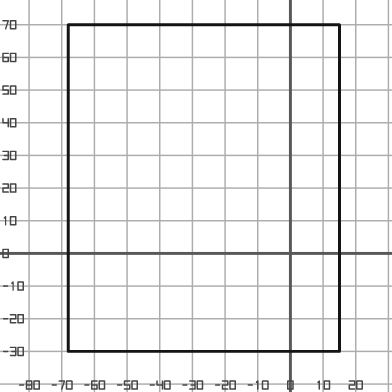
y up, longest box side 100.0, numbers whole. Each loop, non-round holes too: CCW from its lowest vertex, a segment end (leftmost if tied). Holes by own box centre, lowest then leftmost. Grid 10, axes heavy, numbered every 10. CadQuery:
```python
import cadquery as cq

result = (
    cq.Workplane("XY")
    .moveTo(-68.0, -30.0)
    .lineTo(15.0, -30.0)
    .lineTo(15.0, 70.0)
    .lineTo(-68.0, 70.0)
    .close()
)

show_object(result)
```